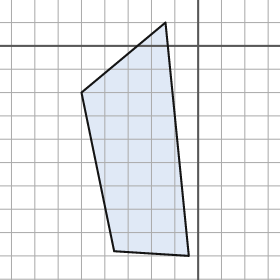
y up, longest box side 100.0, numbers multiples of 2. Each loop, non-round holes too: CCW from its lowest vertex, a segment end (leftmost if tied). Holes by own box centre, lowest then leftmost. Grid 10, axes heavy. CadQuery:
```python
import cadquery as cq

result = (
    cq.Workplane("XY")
    .moveTo(-4.0, -90.0)
    .lineTo(-14.0, 10.0)
    .lineTo(-50.0, -20.0)
    .lineTo(-36.0, -88.0)
    .close()
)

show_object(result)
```